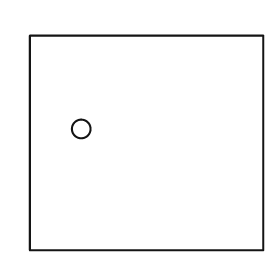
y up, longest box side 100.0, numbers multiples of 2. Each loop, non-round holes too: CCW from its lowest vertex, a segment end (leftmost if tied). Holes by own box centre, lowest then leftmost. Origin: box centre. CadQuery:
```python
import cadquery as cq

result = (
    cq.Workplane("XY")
    .moveTo(-50.0, -46.0)
    .lineTo(50.0, -46.0)
    .lineTo(50.0, 46.0)
    .lineTo(-50.0, 46.0)
    .close()
    .moveTo(-28.0, 6.0)
    .circle(4.0)
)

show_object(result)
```